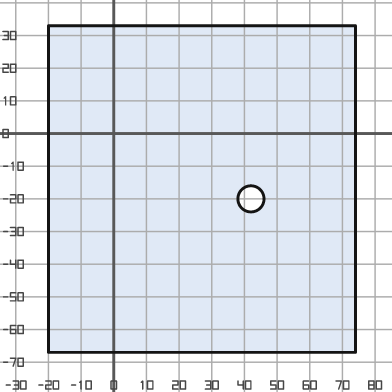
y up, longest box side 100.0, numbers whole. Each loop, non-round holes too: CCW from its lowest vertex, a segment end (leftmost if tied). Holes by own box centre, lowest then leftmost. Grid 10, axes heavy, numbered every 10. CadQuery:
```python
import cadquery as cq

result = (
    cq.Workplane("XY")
    .moveTo(-20.0, -67.0)
    .lineTo(74.0, -67.0)
    .lineTo(74.0, 33.0)
    .lineTo(-20.0, 33.0)
    .close()
    .moveTo(42.0, -20.0)
    .circle(4.0)
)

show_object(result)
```